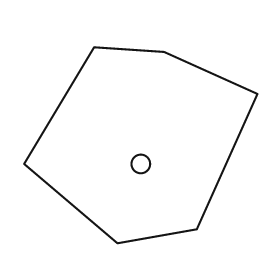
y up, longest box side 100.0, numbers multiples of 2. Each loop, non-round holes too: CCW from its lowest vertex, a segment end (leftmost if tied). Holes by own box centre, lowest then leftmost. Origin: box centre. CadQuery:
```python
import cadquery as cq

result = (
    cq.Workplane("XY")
    .moveTo(-10.0, -42.0)
    .lineTo(24.0, -36.0)
    .lineTo(50.0, 22.0)
    .lineTo(10.0, 40.0)
    .lineTo(-20.0, 42.0)
    .lineTo(-50.0, -8.0)
    .close()
    .moveTo(0.0, -8.0)
    .circle(4.0)
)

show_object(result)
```